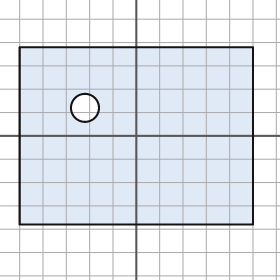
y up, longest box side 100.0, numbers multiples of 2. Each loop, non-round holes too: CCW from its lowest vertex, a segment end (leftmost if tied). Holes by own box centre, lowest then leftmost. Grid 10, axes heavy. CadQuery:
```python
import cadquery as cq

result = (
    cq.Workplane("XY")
    .moveTo(-50.0, -38.0)
    .lineTo(50.0, -38.0)
    .lineTo(50.0, 38.0)
    .lineTo(-50.0, 38.0)
    .close()
    .moveTo(-22.0, 12.0)
    .circle(6.0)
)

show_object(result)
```